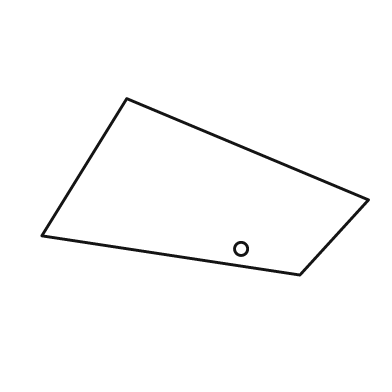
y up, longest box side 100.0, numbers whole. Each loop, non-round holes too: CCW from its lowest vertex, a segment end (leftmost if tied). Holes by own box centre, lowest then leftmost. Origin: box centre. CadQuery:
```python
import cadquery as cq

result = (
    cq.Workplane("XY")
    .moveTo(29.0, -27.0)
    .lineTo(50.0, -4.0)
    .lineTo(-24.0, 27.0)
    .lineTo(-50.0, -15.0)
    .close()
    .moveTo(11.0, -19.0)
    .circle(2.0)
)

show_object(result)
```